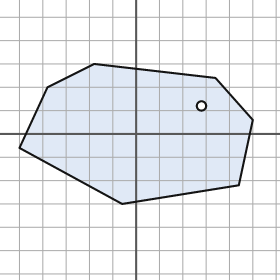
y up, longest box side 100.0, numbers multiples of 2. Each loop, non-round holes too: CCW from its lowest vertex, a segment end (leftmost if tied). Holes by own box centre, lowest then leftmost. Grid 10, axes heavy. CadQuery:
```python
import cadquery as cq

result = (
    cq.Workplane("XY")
    .moveTo(-6.0, -30.0)
    .lineTo(44.0, -22.0)
    .lineTo(50.0, 6.0)
    .lineTo(34.0, 24.0)
    .lineTo(-18.0, 30.0)
    .lineTo(-38.0, 20.0)
    .lineTo(-50.0, -6.0)
    .close()
    .moveTo(28.0, 12.0)
    .circle(2.0)
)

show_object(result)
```